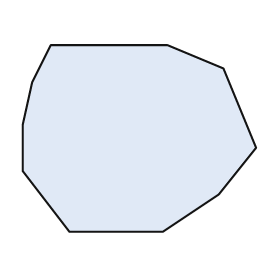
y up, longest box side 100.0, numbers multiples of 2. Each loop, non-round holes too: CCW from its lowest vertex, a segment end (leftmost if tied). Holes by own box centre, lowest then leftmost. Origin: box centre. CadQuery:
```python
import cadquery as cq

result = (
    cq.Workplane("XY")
    .moveTo(-30.0, -40.0)
    .lineTo(10.0, -40.0)
    .lineTo(34.0, -24.0)
    .lineTo(50.0, -4.0)
    .lineTo(36.0, 30.0)
    .lineTo(12.0, 40.0)
    .lineTo(-38.0, 40.0)
    .lineTo(-46.0, 24.0)
    .lineTo(-50.0, 6.0)
    .lineTo(-50.0, -14.0)
    .close()
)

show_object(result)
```